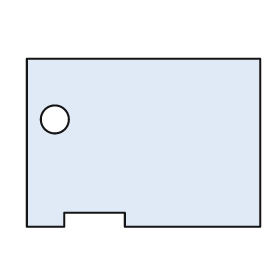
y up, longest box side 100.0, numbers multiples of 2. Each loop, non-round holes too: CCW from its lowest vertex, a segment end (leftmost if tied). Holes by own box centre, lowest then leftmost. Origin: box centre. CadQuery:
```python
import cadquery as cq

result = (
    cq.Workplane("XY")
    .moveTo(-50.0, -36.0)
    .lineTo(-34.0, -36.0)
    .lineTo(-34.0, -30.0)
    .lineTo(-8.0, -30.0)
    .lineTo(-8.0, -36.0)
    .lineTo(50.0, -36.0)
    .lineTo(50.0, 36.0)
    .lineTo(-50.0, 36.0)
    .close()
    .moveTo(-38.0, 10.0)
    .circle(6.0)
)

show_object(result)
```